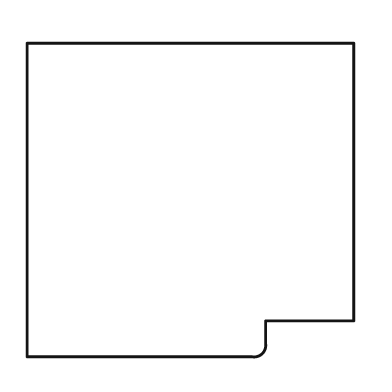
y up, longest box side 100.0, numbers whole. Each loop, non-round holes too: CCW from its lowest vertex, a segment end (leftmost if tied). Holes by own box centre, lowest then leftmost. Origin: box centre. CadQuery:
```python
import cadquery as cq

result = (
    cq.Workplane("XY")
    .moveTo(-50.0, -48.0)
    .lineTo(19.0, -48.0)
    .threePointArc((22.0, -47.0), (23.0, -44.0))
    .lineTo(23.0, -37.0)
    .lineTo(50.0, -37.0)
    .lineTo(50.0, 48.0)
    .lineTo(-50.0, 48.0)
    .close()
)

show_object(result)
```